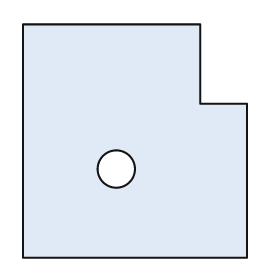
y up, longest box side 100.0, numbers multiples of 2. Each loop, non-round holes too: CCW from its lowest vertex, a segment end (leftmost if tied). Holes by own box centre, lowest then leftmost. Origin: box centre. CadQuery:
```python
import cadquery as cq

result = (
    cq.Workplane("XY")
    .moveTo(-48.0, -50.0)
    .lineTo(48.0, -50.0)
    .lineTo(48.0, 16.0)
    .lineTo(28.0, 16.0)
    .lineTo(28.0, 50.0)
    .lineTo(-48.0, 50.0)
    .close()
    .moveTo(-8.0, -12.0)
    .circle(8.0)
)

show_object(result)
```